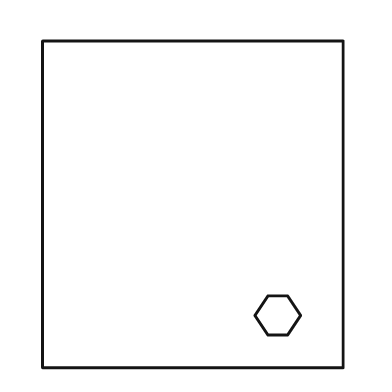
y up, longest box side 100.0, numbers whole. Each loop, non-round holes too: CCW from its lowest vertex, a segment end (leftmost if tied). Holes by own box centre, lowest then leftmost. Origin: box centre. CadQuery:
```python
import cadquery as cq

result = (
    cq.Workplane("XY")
    .moveTo(-46.0, -50.0)
    .lineTo(46.0, -50.0)
    .lineTo(46.0, 50.0)
    .lineTo(-46.0, 50.0)
    .close()
    .moveTo(23.0, -40.0)
    .lineTo(29.0, -40.0)
    .lineTo(33.0, -34.0)
    .lineTo(29.0, -28.0)
    .lineTo(23.0, -28.0)
    .lineTo(19.0, -34.0)
    .close()
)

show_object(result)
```